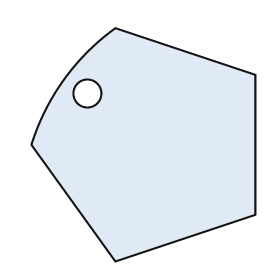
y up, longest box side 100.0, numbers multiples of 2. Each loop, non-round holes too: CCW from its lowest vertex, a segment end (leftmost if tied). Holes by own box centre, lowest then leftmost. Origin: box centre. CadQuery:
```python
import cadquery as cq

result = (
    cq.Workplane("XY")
    .moveTo(-12.0, -50.0)
    .lineTo(48.0, -30.0)
    .lineTo(48.0, 30.0)
    .lineTo(-12.0, 50.0)
    .threePointArc((-34.0, 28.0), (-48.0, 0.0))
    .close()
    .moveTo(-24.0, 22.0)
    .circle(6.0)
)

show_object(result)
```